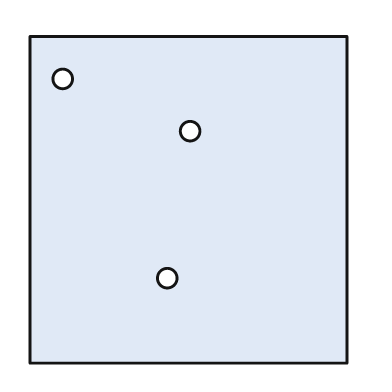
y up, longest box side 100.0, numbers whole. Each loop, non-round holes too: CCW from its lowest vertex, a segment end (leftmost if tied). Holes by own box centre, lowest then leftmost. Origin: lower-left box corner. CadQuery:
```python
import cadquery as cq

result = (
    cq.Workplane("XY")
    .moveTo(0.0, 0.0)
    .lineTo(97.0, 0.0)
    .lineTo(97.0, 100.0)
    .lineTo(0.0, 100.0)
    .close()
    .moveTo(42.0, 26.0)
    .circle(3.0)
    .moveTo(49.0, 71.0)
    .circle(3.0)
    .moveTo(10.0, 87.0)
    .circle(3.0)
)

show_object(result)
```